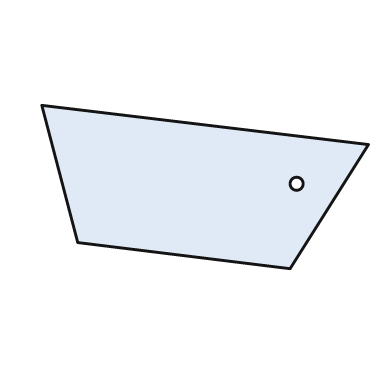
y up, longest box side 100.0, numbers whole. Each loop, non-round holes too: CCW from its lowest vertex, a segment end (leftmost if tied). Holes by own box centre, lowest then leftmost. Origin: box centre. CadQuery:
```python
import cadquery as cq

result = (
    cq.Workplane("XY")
    .moveTo(26.0, -25.0)
    .lineTo(50.0, 13.0)
    .lineTo(-50.0, 25.0)
    .lineTo(-39.0, -17.0)
    .close()
    .moveTo(28.0, 1.0)
    .circle(2.0)
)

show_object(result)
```